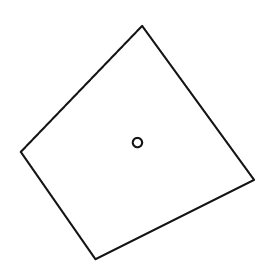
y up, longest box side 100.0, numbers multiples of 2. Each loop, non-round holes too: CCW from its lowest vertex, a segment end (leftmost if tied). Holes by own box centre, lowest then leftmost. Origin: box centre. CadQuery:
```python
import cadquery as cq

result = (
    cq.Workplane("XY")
    .moveTo(-18.0, -50.0)
    .lineTo(50.0, -16.0)
    .lineTo(2.0, 50.0)
    .lineTo(-50.0, -4.0)
    .close()
    .moveTo(0.0, 0.0)
    .circle(2.0)
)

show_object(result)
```